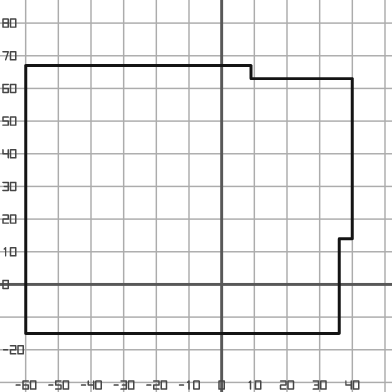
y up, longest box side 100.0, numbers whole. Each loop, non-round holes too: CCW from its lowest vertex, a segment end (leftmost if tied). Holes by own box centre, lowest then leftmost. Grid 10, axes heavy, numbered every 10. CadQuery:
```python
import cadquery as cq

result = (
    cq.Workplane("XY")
    .moveTo(-60.0, -15.0)
    .lineTo(36.0, -15.0)
    .lineTo(36.0, 14.0)
    .lineTo(40.0, 14.0)
    .lineTo(40.0, 63.0)
    .lineTo(9.0, 63.0)
    .lineTo(9.0, 67.0)
    .lineTo(-60.0, 67.0)
    .close()
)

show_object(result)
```